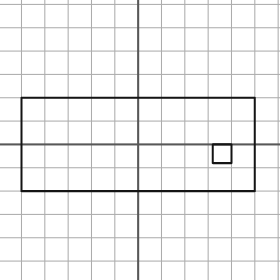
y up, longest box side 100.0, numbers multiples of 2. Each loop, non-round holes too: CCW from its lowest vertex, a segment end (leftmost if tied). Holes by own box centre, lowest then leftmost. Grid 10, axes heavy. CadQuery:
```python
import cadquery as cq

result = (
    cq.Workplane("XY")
    .moveTo(-50.0, -20.0)
    .lineTo(50.0, -20.0)
    .lineTo(50.0, 20.0)
    .lineTo(-50.0, 20.0)
    .close()
    .moveTo(32.0, -8.0)
    .lineTo(40.0, -8.0)
    .lineTo(40.0, 0.0)
    .lineTo(32.0, 0.0)
    .close()
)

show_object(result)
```